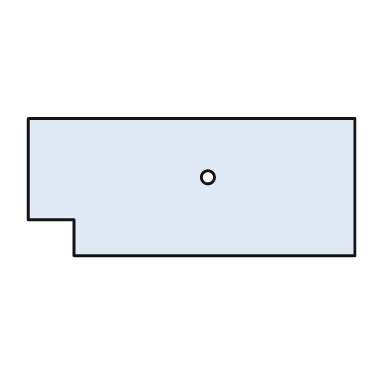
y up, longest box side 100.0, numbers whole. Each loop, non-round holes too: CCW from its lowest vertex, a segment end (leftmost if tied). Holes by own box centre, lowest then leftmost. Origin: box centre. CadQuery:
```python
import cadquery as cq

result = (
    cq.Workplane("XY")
    .moveTo(-36.0, -21.0)
    .lineTo(50.0, -21.0)
    .lineTo(50.0, 21.0)
    .lineTo(-50.0, 21.0)
    .lineTo(-50.0, -10.0)
    .lineTo(-36.0, -10.0)
    .close()
    .moveTo(5.0, 3.0)
    .circle(2.0)
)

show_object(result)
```